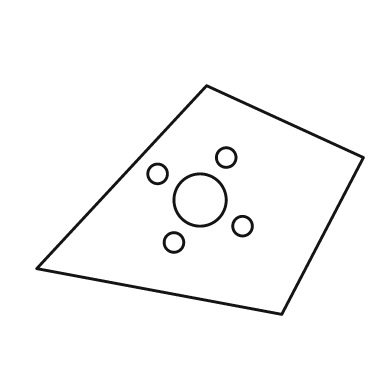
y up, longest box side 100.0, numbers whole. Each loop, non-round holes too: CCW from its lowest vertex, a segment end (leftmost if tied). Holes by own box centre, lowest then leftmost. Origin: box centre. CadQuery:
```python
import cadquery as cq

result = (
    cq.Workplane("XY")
    .moveTo(25.0, -35.0)
    .lineTo(50.0, 13.0)
    .lineTo(2.0, 35.0)
    .lineTo(-50.0, -21.0)
    .close()
    .moveTo(-8.0, -13.0)
    .circle(3.0)
    .moveTo(13.0, -8.0)
    .circle(3.0)
    .moveTo(0.0, 0.0)
    .circle(8.0)
    .moveTo(-13.0, 8.0)
    .circle(3.0)
    .moveTo(8.0, 13.0)
    .circle(3.0)
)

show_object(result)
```